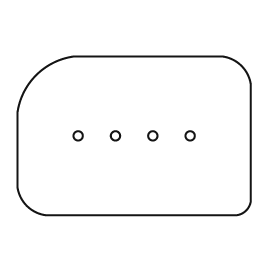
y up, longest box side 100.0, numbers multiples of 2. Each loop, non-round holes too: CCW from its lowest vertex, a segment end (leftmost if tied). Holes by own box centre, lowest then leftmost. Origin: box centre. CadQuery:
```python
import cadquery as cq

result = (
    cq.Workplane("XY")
    .moveTo(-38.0, -34.0)
    .lineTo(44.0, -34.0)
    .threePointArc((48.0, -32.0), (50.0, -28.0))
    .lineTo(50.0, 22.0)
    .threePointArc((46.0, 30.0), (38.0, 34.0))
    .lineTo(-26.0, 34.0)
    .threePointArc((-42.0, 26.0), (-50.0, 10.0))
    .lineTo(-50.0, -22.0)
    .threePointArc((-46.0, -30.0), (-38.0, -34.0))
    .close()
    .moveTo(-24.0, 0.0)
    .circle(2.0)
    .moveTo(-8.0, 0.0)
    .circle(2.0)
    .moveTo(8.0, 0.0)
    .circle(2.0)
    .moveTo(24.0, 0.0)
    .circle(2.0)
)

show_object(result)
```